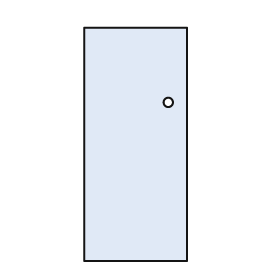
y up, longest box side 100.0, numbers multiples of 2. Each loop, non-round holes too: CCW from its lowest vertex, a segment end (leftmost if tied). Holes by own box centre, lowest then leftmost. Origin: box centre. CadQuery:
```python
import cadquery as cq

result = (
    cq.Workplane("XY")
    .moveTo(-22.0, -50.0)
    .lineTo(22.0, -50.0)
    .lineTo(22.0, 50.0)
    .lineTo(-22.0, 50.0)
    .close()
    .moveTo(14.0, 18.0)
    .circle(2.0)
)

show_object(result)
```